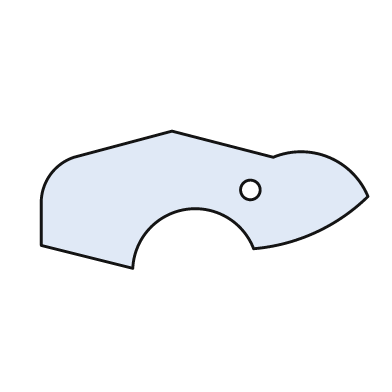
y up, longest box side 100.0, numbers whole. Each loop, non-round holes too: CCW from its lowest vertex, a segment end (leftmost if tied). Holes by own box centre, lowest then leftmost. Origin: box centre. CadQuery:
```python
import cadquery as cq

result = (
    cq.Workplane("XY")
    .moveTo(-22.0, -21.0)
    .threePointArc((-6.0, -3.0), (15.0, -15.0))
    .threePointArc((34.0, -10.0), (50.0, 1.0))
    .threePointArc((38.0, 13.0), (21.0, 13.0))
    .lineTo(-10.0, 21.0)
    .lineTo(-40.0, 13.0)
    .threePointArc((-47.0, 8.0), (-50.0, 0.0))
    .lineTo(-50.0, -14.0)
    .close()
    .moveTo(14.0, 3.0)
    .circle(3.0)
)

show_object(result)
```